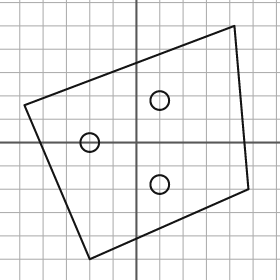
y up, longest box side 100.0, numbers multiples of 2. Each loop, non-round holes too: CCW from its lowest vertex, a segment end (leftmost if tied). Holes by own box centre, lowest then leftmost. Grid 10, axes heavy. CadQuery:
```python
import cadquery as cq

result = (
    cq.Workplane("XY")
    .moveTo(-20.0, -50.0)
    .lineTo(48.0, -20.0)
    .lineTo(42.0, 50.0)
    .lineTo(-48.0, 16.0)
    .close()
    .moveTo(10.0, -18.0)
    .circle(4.0)
    .moveTo(-20.0, 0.0)
    .circle(4.0)
    .moveTo(10.0, 18.0)
    .circle(4.0)
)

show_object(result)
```